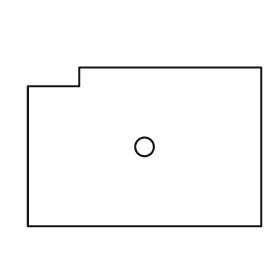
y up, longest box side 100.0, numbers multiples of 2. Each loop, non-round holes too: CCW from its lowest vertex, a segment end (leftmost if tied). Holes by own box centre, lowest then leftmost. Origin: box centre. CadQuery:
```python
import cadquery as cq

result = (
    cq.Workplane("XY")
    .moveTo(-50.0, -34.0)
    .lineTo(50.0, -34.0)
    .lineTo(50.0, 34.0)
    .lineTo(-28.0, 34.0)
    .lineTo(-28.0, 26.0)
    .lineTo(-50.0, 26.0)
    .close()
    .moveTo(0.0, 0.0)
    .circle(4.0)
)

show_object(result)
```